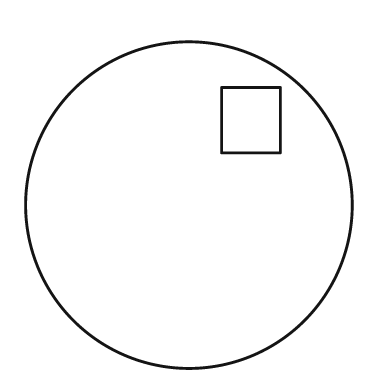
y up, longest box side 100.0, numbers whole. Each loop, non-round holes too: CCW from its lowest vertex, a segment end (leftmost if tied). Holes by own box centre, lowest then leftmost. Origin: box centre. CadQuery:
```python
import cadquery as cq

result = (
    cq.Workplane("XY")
    .moveTo(0.0, 0.0)
    .circle(50.0)
    .moveTo(10.0, 16.0)
    .lineTo(28.0, 16.0)
    .lineTo(28.0, 36.0)
    .lineTo(10.0, 36.0)
    .close()
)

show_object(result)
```